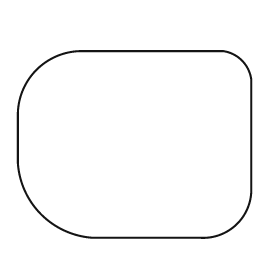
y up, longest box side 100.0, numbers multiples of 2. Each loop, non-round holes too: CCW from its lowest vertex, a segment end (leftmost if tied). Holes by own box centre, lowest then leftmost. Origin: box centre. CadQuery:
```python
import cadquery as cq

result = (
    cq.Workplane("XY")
    .moveTo(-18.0, -40.0)
    .lineTo(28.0, -40.0)
    .threePointArc((44.0, -34.0), (50.0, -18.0))
    .lineTo(50.0, 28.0)
    .threePointArc((46.0, 36.0), (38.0, 40.0))
    .lineTo(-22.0, 40.0)
    .threePointArc((-42.0, 32.0), (-50.0, 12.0))
    .lineTo(-50.0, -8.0)
    .threePointArc((-40.0, -30.0), (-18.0, -40.0))
    .close()
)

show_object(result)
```